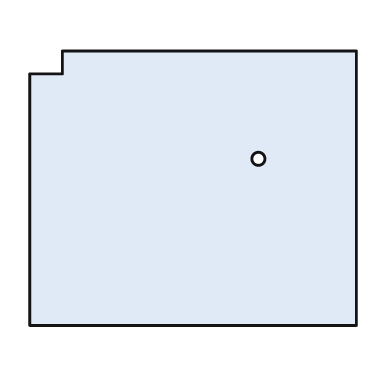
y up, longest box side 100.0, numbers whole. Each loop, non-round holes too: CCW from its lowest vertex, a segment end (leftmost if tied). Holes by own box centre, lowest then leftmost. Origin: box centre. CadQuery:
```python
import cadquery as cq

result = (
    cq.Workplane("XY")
    .moveTo(-50.0, -42.0)
    .lineTo(50.0, -42.0)
    .lineTo(50.0, 42.0)
    .lineTo(-40.0, 42.0)
    .lineTo(-40.0, 35.0)
    .lineTo(-50.0, 35.0)
    .close()
    .moveTo(20.0, 9.0)
    .circle(2.0)
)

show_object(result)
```